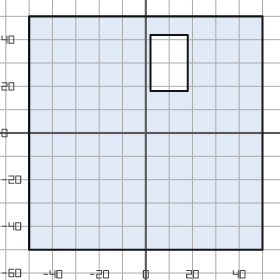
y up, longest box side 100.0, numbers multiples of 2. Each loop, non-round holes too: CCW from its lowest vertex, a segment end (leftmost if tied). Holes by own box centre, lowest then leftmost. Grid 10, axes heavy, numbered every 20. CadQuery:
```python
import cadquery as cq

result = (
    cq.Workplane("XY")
    .moveTo(-50.0, -50.0)
    .lineTo(50.0, -50.0)
    .lineTo(50.0, 50.0)
    .lineTo(-50.0, 50.0)
    .close()
    .moveTo(2.0, 18.0)
    .lineTo(18.0, 18.0)
    .lineTo(18.0, 42.0)
    .lineTo(2.0, 42.0)
    .close()
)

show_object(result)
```